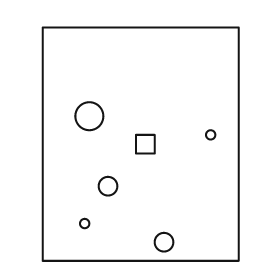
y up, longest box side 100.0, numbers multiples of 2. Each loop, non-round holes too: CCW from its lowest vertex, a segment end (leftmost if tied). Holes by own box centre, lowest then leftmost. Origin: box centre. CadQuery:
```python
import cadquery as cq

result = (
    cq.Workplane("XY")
    .moveTo(-42.0, -50.0)
    .lineTo(42.0, -50.0)
    .lineTo(42.0, 50.0)
    .lineTo(-42.0, 50.0)
    .close()
    .moveTo(10.0, -42.0)
    .circle(4.0)
    .moveTo(-24.0, -34.0)
    .circle(2.0)
    .moveTo(-14.0, -18.0)
    .circle(4.0)
    .moveTo(-2.0, -4.0)
    .lineTo(6.0, -4.0)
    .lineTo(6.0, 4.0)
    .lineTo(-2.0, 4.0)
    .close()
    .moveTo(30.0, 4.0)
    .circle(2.0)
    .moveTo(-22.0, 12.0)
    .circle(6.0)
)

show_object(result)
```